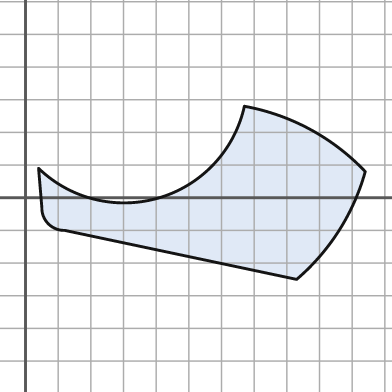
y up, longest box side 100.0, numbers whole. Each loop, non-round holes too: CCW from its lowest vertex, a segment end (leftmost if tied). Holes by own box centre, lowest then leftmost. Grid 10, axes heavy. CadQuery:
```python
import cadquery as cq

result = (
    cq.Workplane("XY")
    .moveTo(83.0, -25.0)
    .threePointArc((96.0, -10.0), (104.0, 8.0))
    .threePointArc((87.0, 21.0), (67.0, 28.0))
    .threePointArc((41.0, 0.0), (4.0, 9.0))
    .lineTo(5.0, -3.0)
    .threePointArc((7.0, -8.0), (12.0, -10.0))
    .close()
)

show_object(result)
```